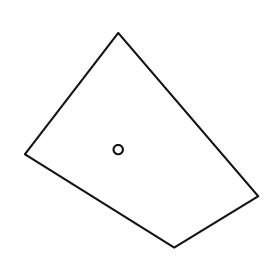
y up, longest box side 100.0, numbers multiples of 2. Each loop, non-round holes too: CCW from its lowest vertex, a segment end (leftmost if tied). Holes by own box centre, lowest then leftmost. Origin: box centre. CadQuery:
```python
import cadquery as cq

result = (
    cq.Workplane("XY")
    .moveTo(14.0, -46.0)
    .lineTo(50.0, -24.0)
    .lineTo(-10.0, 46.0)
    .lineTo(-50.0, -6.0)
    .close()
    .moveTo(-10.0, -4.0)
    .circle(2.0)
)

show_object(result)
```